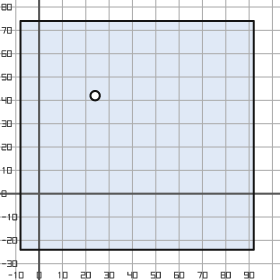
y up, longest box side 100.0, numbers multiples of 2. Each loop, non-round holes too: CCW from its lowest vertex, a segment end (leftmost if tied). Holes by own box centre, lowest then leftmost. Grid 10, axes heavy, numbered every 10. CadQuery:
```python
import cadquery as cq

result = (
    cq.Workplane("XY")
    .moveTo(-8.0, -24.0)
    .lineTo(92.0, -24.0)
    .lineTo(92.0, 74.0)
    .lineTo(-8.0, 74.0)
    .close()
    .moveTo(24.0, 42.0)
    .circle(2.0)
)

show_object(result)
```